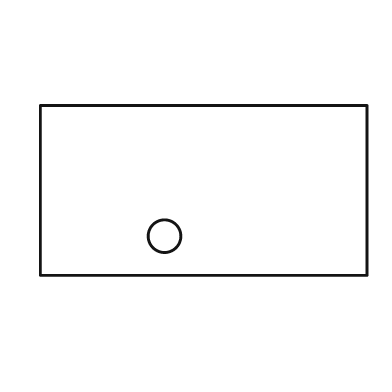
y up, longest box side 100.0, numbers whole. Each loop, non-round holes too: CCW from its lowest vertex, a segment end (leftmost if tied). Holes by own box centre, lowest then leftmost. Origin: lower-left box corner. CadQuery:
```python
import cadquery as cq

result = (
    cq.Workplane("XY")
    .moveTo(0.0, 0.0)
    .lineTo(100.0, 0.0)
    .lineTo(100.0, 52.0)
    .lineTo(0.0, 52.0)
    .close()
    .moveTo(38.0, 12.0)
    .circle(5.0)
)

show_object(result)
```